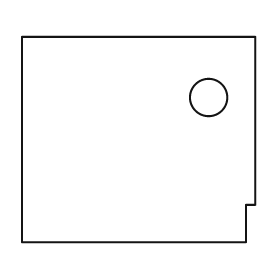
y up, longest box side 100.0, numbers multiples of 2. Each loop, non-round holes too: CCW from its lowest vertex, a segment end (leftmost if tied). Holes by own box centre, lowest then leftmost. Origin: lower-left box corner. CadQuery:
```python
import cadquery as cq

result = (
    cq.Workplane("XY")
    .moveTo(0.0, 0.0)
    .lineTo(96.0, 0.0)
    .lineTo(96.0, 16.0)
    .lineTo(100.0, 16.0)
    .lineTo(100.0, 88.0)
    .lineTo(0.0, 88.0)
    .close()
    .moveTo(80.0, 62.0)
    .circle(8.0)
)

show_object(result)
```